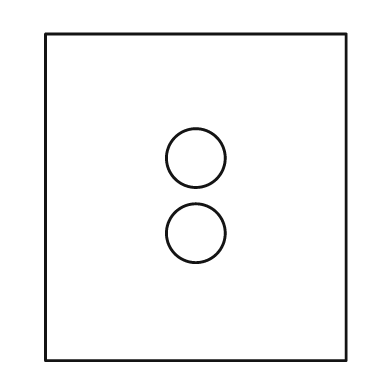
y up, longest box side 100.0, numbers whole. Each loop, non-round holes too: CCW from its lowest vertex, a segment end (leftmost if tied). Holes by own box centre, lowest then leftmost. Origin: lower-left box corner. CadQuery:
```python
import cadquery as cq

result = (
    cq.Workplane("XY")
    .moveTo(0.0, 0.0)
    .lineTo(92.0, 0.0)
    .lineTo(92.0, 100.0)
    .lineTo(0.0, 100.0)
    .close()
    .moveTo(46.0, 39.0)
    .circle(9.0)
    .moveTo(46.0, 62.0)
    .circle(9.0)
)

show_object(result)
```